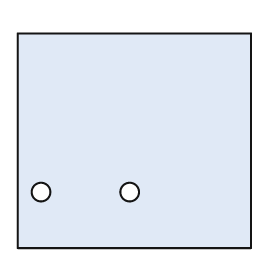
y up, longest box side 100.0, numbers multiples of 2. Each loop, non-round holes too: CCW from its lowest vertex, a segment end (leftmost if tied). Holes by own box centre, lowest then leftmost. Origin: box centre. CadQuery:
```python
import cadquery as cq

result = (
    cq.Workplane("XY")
    .moveTo(-50.0, -46.0)
    .lineTo(50.0, -46.0)
    .lineTo(50.0, 46.0)
    .lineTo(-50.0, 46.0)
    .close()
    .moveTo(-40.0, -22.0)
    .circle(4.0)
    .moveTo(-2.0, -22.0)
    .circle(4.0)
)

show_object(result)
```